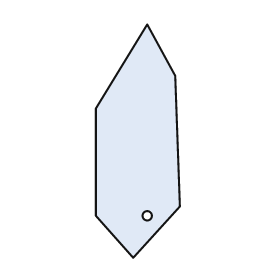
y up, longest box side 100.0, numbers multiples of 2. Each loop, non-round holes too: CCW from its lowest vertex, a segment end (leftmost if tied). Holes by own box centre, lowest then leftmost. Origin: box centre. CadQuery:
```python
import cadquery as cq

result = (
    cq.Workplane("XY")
    .moveTo(-2.0, -50.0)
    .lineTo(18.0, -28.0)
    .lineTo(16.0, 28.0)
    .lineTo(4.0, 50.0)
    .lineTo(-18.0, 14.0)
    .lineTo(-18.0, -32.0)
    .close()
    .moveTo(4.0, -32.0)
    .circle(2.0)
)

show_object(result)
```